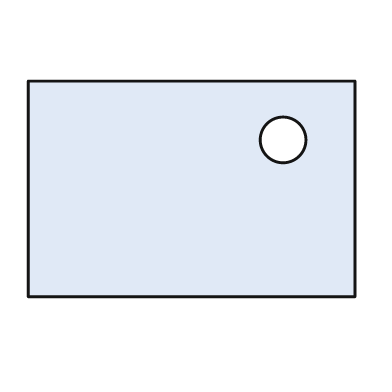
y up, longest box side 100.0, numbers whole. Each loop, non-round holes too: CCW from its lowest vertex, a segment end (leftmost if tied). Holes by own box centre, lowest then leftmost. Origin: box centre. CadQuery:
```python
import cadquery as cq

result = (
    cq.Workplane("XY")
    .moveTo(-50.0, -33.0)
    .lineTo(50.0, -33.0)
    .lineTo(50.0, 33.0)
    .lineTo(-50.0, 33.0)
    .close()
    .moveTo(28.0, 15.0)
    .circle(7.0)
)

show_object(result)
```